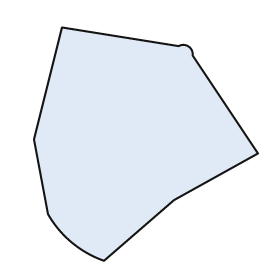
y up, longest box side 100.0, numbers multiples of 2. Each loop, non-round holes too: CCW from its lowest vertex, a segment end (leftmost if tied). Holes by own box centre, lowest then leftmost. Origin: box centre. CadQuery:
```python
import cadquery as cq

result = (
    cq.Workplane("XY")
    .moveTo(-18.0, -50.0)
    .lineTo(12.0, -24.0)
    .lineTo(48.0, -4.0)
    .lineTo(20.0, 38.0)
    .threePointArc((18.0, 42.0), (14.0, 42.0))
    .lineTo(-36.0, 50.0)
    .lineTo(-48.0, 2.0)
    .lineTo(-42.0, -30.0)
    .threePointArc((-32.0, -42.0), (-18.0, -50.0))
    .close()
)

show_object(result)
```